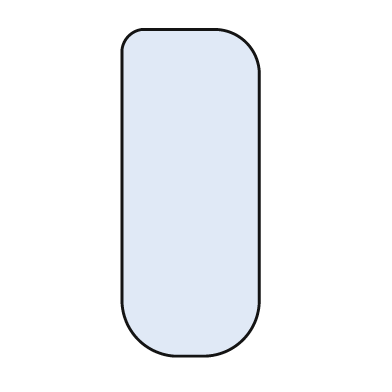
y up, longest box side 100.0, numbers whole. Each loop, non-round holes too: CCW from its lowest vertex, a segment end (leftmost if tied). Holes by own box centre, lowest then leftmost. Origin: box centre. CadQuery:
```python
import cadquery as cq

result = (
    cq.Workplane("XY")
    .moveTo(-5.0, -50.0)
    .lineTo(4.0, -50.0)
    .threePointArc((16.0, -45.0), (21.0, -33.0))
    .lineTo(21.0, 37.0)
    .threePointArc((17.0, 46.0), (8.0, 50.0))
    .lineTo(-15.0, 50.0)
    .threePointArc((-19.0, 48.0), (-21.0, 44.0))
    .lineTo(-21.0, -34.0)
    .threePointArc((-16.0, -45.0), (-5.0, -50.0))
    .close()
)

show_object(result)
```